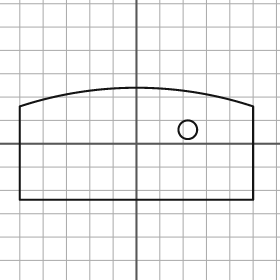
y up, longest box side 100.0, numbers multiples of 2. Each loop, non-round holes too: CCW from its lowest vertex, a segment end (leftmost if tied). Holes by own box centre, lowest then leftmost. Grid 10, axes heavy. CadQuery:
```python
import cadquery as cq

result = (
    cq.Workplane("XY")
    .moveTo(-50.0, -24.0)
    .lineTo(50.0, -24.0)
    .lineTo(50.0, 16.0)
    .threePointArc((0.0, 24.0), (-50.0, 16.0))
    .close()
    .moveTo(22.0, 6.0)
    .circle(4.0)
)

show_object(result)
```